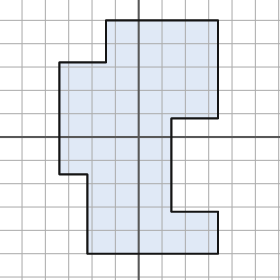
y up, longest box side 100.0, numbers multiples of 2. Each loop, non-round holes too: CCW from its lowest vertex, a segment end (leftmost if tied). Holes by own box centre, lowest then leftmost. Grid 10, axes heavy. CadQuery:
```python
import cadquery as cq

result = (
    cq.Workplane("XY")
    .moveTo(-22.0, -50.0)
    .lineTo(34.0, -50.0)
    .lineTo(34.0, -32.0)
    .lineTo(14.0, -32.0)
    .lineTo(14.0, 8.0)
    .lineTo(34.0, 8.0)
    .lineTo(34.0, 50.0)
    .lineTo(-14.0, 50.0)
    .lineTo(-14.0, 32.0)
    .lineTo(-34.0, 32.0)
    .lineTo(-34.0, -16.0)
    .lineTo(-22.0, -16.0)
    .close()
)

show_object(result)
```